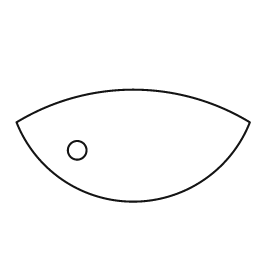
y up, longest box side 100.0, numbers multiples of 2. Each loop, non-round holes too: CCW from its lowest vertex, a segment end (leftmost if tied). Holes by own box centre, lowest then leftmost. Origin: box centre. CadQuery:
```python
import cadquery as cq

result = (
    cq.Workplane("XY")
    .moveTo(-50.0, 10.0)
    .threePointArc((0.0, -24.0), (50.0, 10.0))
    .threePointArc((0.0, 24.0), (-50.0, 10.0))
    .close()
    .moveTo(-24.0, -2.0)
    .circle(4.0)
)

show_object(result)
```